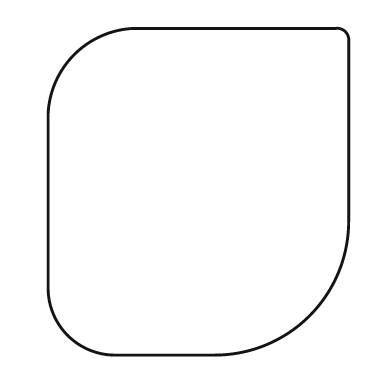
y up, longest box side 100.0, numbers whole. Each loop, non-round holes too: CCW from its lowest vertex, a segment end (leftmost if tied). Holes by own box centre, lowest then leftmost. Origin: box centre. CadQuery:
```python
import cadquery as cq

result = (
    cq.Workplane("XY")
    .moveTo(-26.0, -50.0)
    .lineTo(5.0, -50.0)
    .threePointArc((34.0, -38.0), (46.0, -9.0))
    .lineTo(46.0, 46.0)
    .threePointArc((45.0, 49.0), (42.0, 50.0))
    .lineTo(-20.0, 50.0)
    .threePointArc((-38.0, 42.0), (-46.0, 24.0))
    .lineTo(-46.0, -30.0)
    .threePointArc((-40.0, -44.0), (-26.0, -50.0))
    .close()
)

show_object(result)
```